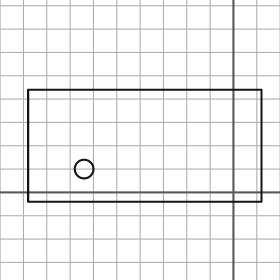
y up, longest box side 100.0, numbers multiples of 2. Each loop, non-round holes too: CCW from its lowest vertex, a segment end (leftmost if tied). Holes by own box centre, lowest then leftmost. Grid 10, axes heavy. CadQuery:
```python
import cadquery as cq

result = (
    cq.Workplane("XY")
    .moveTo(-88.0, -4.0)
    .lineTo(12.0, -4.0)
    .lineTo(12.0, 44.0)
    .lineTo(-88.0, 44.0)
    .close()
    .moveTo(-64.0, 10.0)
    .circle(4.0)
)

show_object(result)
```